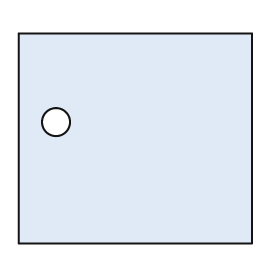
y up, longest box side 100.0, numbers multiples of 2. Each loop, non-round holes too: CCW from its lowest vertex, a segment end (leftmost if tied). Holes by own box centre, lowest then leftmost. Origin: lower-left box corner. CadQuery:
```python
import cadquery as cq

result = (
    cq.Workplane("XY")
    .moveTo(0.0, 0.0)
    .lineTo(100.0, 0.0)
    .lineTo(100.0, 90.0)
    .lineTo(0.0, 90.0)
    .close()
    .moveTo(16.0, 52.0)
    .circle(6.0)
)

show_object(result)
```